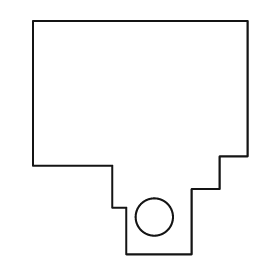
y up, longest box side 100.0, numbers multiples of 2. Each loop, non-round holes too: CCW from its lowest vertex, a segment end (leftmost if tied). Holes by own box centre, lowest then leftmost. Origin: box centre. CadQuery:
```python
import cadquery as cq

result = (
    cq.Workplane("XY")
    .moveTo(-6.0, -50.0)
    .lineTo(22.0, -50.0)
    .lineTo(22.0, -22.0)
    .lineTo(34.0, -22.0)
    .lineTo(34.0, -8.0)
    .lineTo(46.0, -8.0)
    .lineTo(46.0, 50.0)
    .lineTo(-46.0, 50.0)
    .lineTo(-46.0, -12.0)
    .lineTo(-12.0, -12.0)
    .lineTo(-12.0, -30.0)
    .lineTo(-6.0, -30.0)
    .close()
    .moveTo(6.0, -34.0)
    .circle(8.0)
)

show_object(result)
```